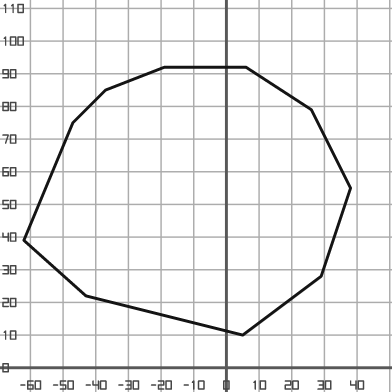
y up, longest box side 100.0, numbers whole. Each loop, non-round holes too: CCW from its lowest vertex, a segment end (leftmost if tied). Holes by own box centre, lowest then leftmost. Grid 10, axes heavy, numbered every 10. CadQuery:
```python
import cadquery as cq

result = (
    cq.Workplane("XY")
    .moveTo(5.0, 10.0)
    .lineTo(29.0, 28.0)
    .lineTo(38.0, 55.0)
    .lineTo(26.0, 79.0)
    .lineTo(6.0, 92.0)
    .lineTo(-19.0, 92.0)
    .lineTo(-37.0, 85.0)
    .lineTo(-47.0, 75.0)
    .lineTo(-62.0, 39.0)
    .lineTo(-43.0, 22.0)
    .close()
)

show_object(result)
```